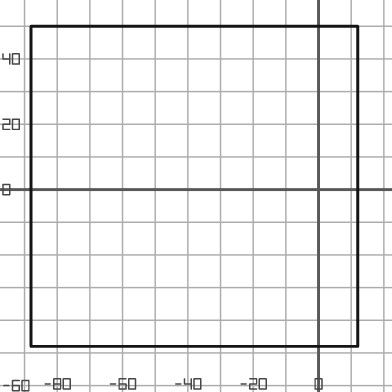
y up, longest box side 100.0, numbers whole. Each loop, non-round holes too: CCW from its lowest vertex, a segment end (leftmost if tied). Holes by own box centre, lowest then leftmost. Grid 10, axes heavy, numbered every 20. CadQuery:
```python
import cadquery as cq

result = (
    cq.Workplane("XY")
    .moveTo(-88.0, -48.0)
    .lineTo(12.0, -48.0)
    .lineTo(12.0, 50.0)
    .lineTo(-88.0, 50.0)
    .close()
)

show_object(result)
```